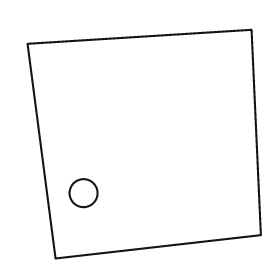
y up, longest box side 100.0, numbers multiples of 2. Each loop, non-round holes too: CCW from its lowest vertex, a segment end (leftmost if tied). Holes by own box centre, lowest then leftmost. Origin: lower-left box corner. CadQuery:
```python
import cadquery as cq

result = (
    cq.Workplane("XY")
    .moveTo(12.0, 0.0)
    .lineTo(100.0, 10.0)
    .lineTo(96.0, 98.0)
    .lineTo(0.0, 92.0)
    .close()
    .moveTo(24.0, 28.0)
    .circle(6.0)
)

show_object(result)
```